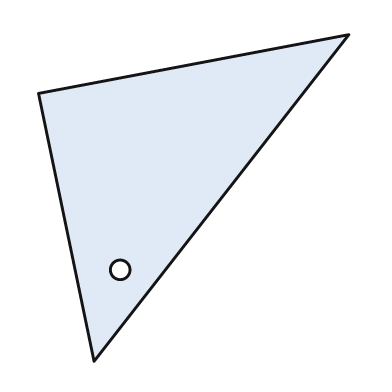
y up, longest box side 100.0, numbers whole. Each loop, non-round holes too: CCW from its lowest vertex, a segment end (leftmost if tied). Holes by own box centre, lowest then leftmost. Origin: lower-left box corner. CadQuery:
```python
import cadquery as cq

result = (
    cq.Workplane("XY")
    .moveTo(17.0, 0.0)
    .lineTo(95.0, 100.0)
    .lineTo(0.0, 82.0)
    .close()
    .moveTo(25.0, 28.0)
    .circle(3.0)
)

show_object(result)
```